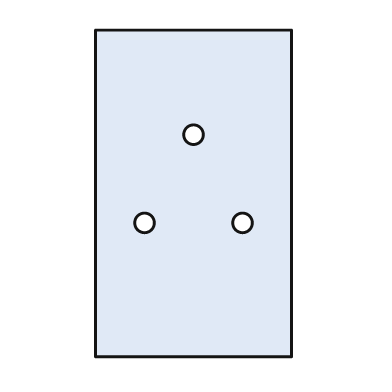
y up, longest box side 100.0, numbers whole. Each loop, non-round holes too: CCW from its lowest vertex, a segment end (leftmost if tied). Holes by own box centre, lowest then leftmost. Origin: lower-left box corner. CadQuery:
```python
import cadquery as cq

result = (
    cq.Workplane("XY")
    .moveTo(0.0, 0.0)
    .lineTo(60.0, 0.0)
    .lineTo(60.0, 100.0)
    .lineTo(0.0, 100.0)
    .close()
    .moveTo(15.0, 41.0)
    .circle(3.0)
    .moveTo(45.0, 41.0)
    .circle(3.0)
    .moveTo(30.0, 68.0)
    .circle(3.0)
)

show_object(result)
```